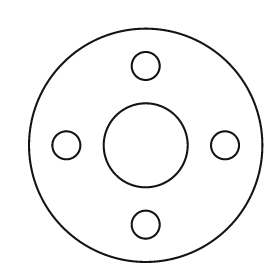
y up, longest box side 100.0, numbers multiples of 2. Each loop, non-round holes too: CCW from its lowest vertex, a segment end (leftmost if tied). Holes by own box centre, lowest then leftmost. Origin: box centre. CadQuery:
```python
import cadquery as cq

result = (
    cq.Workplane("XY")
    .moveTo(0.0, 0.0)
    .circle(50.0)
    .moveTo(0.0, -34.0)
    .circle(6.0)
    .moveTo(-34.0, 0.0)
    .circle(6.0)
    .moveTo(0.0, 0.0)
    .circle(18.0)
    .moveTo(34.0, 0.0)
    .circle(6.0)
    .moveTo(0.0, 34.0)
    .circle(6.0)
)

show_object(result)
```